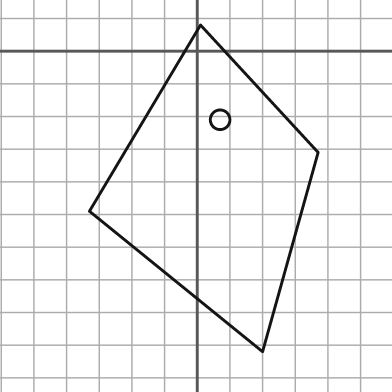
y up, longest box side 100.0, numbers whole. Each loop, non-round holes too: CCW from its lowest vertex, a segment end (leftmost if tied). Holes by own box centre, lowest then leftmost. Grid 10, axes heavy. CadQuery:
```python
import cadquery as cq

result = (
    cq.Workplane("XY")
    .moveTo(20.0, -92.0)
    .lineTo(37.0, -31.0)
    .lineTo(1.0, 8.0)
    .lineTo(-33.0, -49.0)
    .close()
    .moveTo(7.0, -21.0)
    .circle(3.0)
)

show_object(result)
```